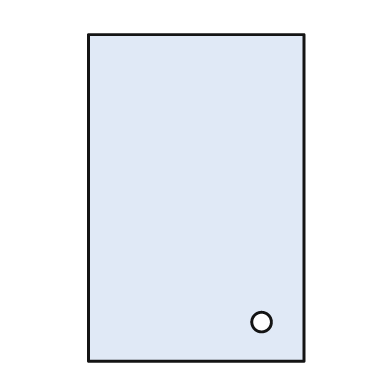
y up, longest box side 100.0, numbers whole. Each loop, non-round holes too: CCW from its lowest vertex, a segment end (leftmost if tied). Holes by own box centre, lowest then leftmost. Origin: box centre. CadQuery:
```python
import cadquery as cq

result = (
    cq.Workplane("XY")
    .moveTo(-33.0, -50.0)
    .lineTo(33.0, -50.0)
    .lineTo(33.0, 50.0)
    .lineTo(-33.0, 50.0)
    .close()
    .moveTo(20.0, -38.0)
    .circle(3.0)
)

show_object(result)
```